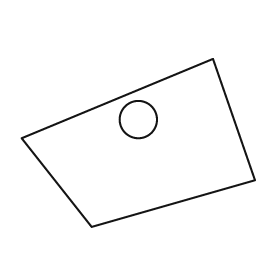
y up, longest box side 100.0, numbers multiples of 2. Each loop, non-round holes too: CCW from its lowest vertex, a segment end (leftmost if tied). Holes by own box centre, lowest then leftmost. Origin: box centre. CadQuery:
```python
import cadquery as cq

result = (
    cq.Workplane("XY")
    .moveTo(-20.0, -36.0)
    .lineTo(50.0, -16.0)
    .lineTo(32.0, 36.0)
    .lineTo(-50.0, 2.0)
    .close()
    .moveTo(0.0, 10.0)
    .circle(8.0)
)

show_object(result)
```